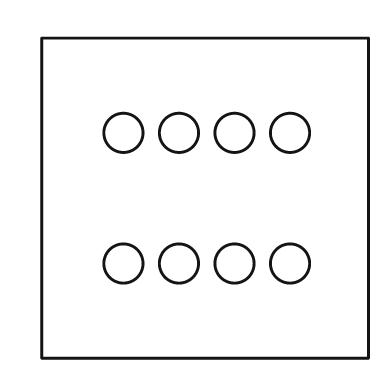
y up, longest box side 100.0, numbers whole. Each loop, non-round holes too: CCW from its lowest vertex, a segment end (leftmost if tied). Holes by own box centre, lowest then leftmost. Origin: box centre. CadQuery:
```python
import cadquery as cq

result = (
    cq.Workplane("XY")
    .moveTo(-50.0, -49.0)
    .lineTo(50.0, -49.0)
    .lineTo(50.0, 49.0)
    .lineTo(-50.0, 49.0)
    .close()
    .moveTo(-25.0, -20.0)
    .circle(6.0)
    .moveTo(-8.0, -20.0)
    .circle(6.0)
    .moveTo(9.0, -20.0)
    .circle(6.0)
    .moveTo(26.0, -20.0)
    .circle(6.0)
    .moveTo(-25.0, 20.0)
    .circle(6.0)
    .moveTo(-8.0, 20.0)
    .circle(6.0)
    .moveTo(9.0, 20.0)
    .circle(6.0)
    .moveTo(26.0, 20.0)
    .circle(6.0)
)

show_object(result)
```